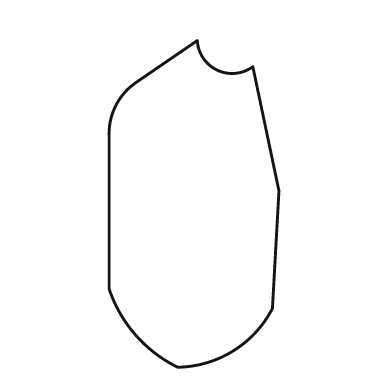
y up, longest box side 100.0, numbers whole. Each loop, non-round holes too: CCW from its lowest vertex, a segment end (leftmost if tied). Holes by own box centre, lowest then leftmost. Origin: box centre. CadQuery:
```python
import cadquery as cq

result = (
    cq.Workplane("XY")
    .moveTo(-5.0, -50.0)
    .threePointArc((12.0, -45.0), (24.0, -32.0))
    .lineTo(26.0, 4.0)
    .lineTo(18.0, 42.0)
    .threePointArc((7.0, 41.0), (1.0, 50.0))
    .lineTo(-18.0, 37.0)
    .threePointArc((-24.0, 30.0), (-26.0, 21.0))
    .lineTo(-26.0, -26.0)
    .threePointArc((-18.0, -40.0), (-5.0, -50.0))
    .close()
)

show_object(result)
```